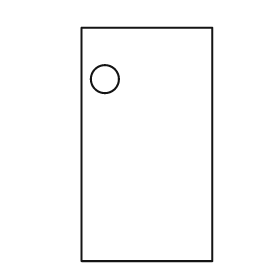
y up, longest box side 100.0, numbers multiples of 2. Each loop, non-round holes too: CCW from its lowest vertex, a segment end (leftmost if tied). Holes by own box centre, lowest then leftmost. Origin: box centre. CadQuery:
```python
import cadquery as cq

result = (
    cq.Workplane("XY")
    .moveTo(-28.0, -50.0)
    .lineTo(28.0, -50.0)
    .lineTo(28.0, 50.0)
    .lineTo(-28.0, 50.0)
    .close()
    .moveTo(-18.0, 28.0)
    .circle(6.0)
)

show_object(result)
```